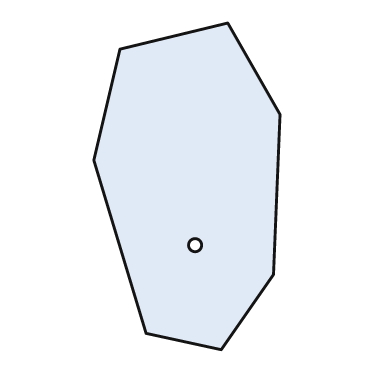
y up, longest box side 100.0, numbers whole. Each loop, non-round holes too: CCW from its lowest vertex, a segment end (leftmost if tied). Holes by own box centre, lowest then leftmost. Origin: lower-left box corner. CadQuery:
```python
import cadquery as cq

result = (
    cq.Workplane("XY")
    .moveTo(39.0, 0.0)
    .lineTo(55.0, 23.0)
    .lineTo(57.0, 72.0)
    .lineTo(41.0, 100.0)
    .lineTo(8.0, 92.0)
    .lineTo(0.0, 58.0)
    .lineTo(16.0, 5.0)
    .close()
    .moveTo(31.0, 32.0)
    .circle(2.0)
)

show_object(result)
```